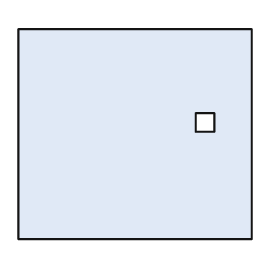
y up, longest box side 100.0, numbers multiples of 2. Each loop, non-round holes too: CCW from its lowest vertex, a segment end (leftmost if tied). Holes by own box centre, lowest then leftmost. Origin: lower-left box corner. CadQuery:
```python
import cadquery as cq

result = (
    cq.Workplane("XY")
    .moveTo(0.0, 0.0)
    .lineTo(100.0, 0.0)
    .lineTo(100.0, 90.0)
    .lineTo(0.0, 90.0)
    .close()
    .moveTo(76.0, 46.0)
    .lineTo(84.0, 46.0)
    .lineTo(84.0, 54.0)
    .lineTo(76.0, 54.0)
    .close()
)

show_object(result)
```